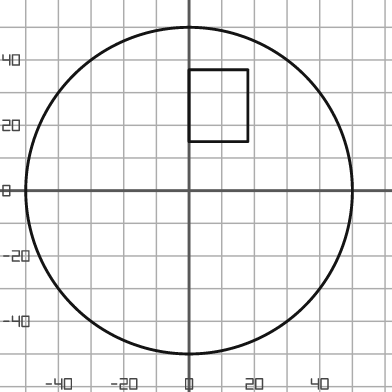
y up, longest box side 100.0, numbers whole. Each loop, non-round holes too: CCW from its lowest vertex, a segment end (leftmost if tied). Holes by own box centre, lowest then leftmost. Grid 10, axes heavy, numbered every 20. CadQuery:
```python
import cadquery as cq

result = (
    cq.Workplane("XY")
    .moveTo(0.0, 0.0)
    .circle(50.0)
    .moveTo(0.0, 15.0)
    .lineTo(18.0, 15.0)
    .lineTo(18.0, 37.0)
    .lineTo(0.0, 37.0)
    .close()
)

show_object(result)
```